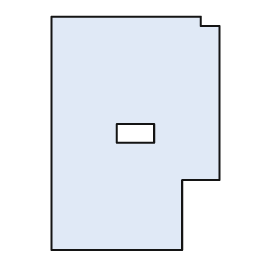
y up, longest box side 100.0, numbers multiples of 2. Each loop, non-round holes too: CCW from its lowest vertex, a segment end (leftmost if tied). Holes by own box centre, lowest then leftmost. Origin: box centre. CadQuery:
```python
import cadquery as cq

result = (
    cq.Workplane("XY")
    .moveTo(-36.0, -50.0)
    .lineTo(20.0, -50.0)
    .lineTo(20.0, -20.0)
    .lineTo(36.0, -20.0)
    .lineTo(36.0, 46.0)
    .lineTo(28.0, 46.0)
    .lineTo(28.0, 50.0)
    .lineTo(-36.0, 50.0)
    .close()
    .moveTo(-8.0, -4.0)
    .lineTo(8.0, -4.0)
    .lineTo(8.0, 4.0)
    .lineTo(-8.0, 4.0)
    .close()
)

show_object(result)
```